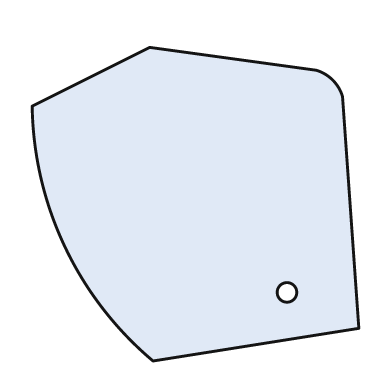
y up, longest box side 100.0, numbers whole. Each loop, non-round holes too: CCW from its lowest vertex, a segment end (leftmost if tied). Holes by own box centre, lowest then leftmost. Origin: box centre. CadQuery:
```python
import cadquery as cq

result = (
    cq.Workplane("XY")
    .moveTo(-13.0, -48.0)
    .lineTo(50.0, -38.0)
    .lineTo(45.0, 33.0)
    .threePointArc((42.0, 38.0), (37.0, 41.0))
    .lineTo(-14.0, 48.0)
    .lineTo(-50.0, 30.0)
    .threePointArc((-40.0, -13.0), (-13.0, -48.0))
    .close()
    .moveTo(28.0, -27.0)
    .circle(3.0)
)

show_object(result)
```